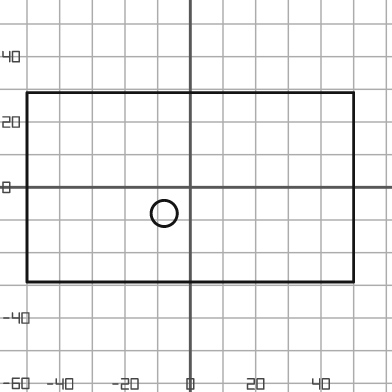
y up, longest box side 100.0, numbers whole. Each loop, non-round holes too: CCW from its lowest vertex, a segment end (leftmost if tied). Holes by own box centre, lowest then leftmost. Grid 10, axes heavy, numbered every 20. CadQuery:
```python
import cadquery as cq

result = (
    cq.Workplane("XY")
    .moveTo(-50.0, -29.0)
    .lineTo(50.0, -29.0)
    .lineTo(50.0, 29.0)
    .lineTo(-50.0, 29.0)
    .close()
    .moveTo(-8.0, -8.0)
    .circle(4.0)
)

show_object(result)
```